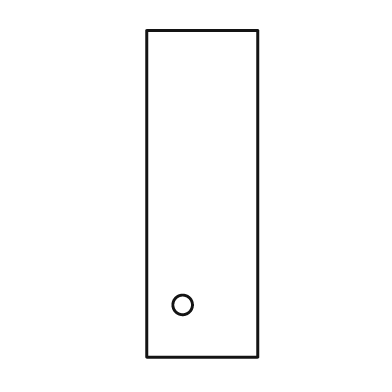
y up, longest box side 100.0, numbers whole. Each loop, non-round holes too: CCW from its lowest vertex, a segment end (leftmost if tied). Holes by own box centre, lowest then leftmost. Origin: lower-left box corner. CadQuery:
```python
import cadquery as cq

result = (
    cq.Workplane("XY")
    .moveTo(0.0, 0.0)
    .lineTo(34.0, 0.0)
    .lineTo(34.0, 100.0)
    .lineTo(0.0, 100.0)
    .close()
    .moveTo(11.0, 16.0)
    .circle(3.0)
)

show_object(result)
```